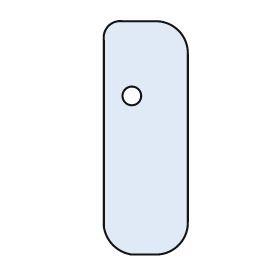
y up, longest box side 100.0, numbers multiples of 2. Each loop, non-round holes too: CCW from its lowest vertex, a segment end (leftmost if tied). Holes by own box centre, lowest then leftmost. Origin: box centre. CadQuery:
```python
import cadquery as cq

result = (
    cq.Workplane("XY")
    .moveTo(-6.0, -50.0)
    .lineTo(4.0, -50.0)
    .threePointArc((14.0, -46.0), (18.0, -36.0))
    .lineTo(18.0, 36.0)
    .threePointArc((14.0, 46.0), (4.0, 50.0))
    .lineTo(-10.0, 50.0)
    .threePointArc((-16.0, 48.0), (-18.0, 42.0))
    .lineTo(-18.0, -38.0)
    .threePointArc((-14.0, -46.0), (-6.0, -50.0))
    .close()
    .moveTo(-6.0, 18.0)
    .circle(4.0)
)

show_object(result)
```